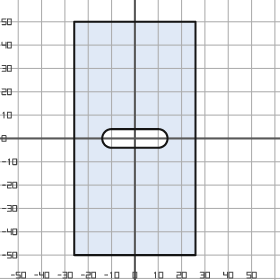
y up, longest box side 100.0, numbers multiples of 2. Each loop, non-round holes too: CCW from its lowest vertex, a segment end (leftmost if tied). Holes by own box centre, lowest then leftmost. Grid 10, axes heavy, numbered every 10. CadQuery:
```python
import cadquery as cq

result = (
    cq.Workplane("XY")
    .moveTo(-26.0, -50.0)
    .lineTo(26.0, -50.0)
    .lineTo(26.0, 50.0)
    .lineTo(-26.0, 50.0)
    .close()
    .moveTo(-10.0, -4.0)
    .lineTo(10.0, -4.0)
    .threePointArc((14.0, 0.0), (10.0, 4.0))
    .lineTo(-10.0, 4.0)
    .threePointArc((-14.0, 0.0), (-10.0, -4.0))
    .close()
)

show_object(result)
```